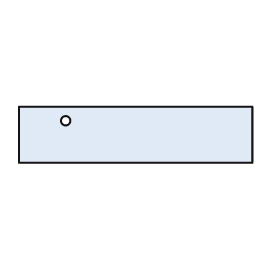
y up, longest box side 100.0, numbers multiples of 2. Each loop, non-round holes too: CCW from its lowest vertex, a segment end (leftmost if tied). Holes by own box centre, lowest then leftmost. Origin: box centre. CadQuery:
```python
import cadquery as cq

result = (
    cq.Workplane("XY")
    .moveTo(-50.0, -12.0)
    .lineTo(50.0, -12.0)
    .lineTo(50.0, 12.0)
    .lineTo(-50.0, 12.0)
    .close()
    .moveTo(-30.0, 6.0)
    .circle(2.0)
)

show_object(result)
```